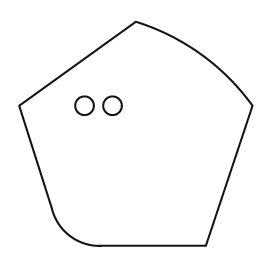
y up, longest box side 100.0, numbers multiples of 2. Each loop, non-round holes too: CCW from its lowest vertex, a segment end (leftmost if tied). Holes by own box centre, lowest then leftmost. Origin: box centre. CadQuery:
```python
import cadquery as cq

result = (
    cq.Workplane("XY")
    .moveTo(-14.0, -48.0)
    .lineTo(30.0, -48.0)
    .lineTo(50.0, 12.0)
    .threePointArc((28.0, 34.0), (0.0, 48.0))
    .lineTo(-50.0, 12.0)
    .lineTo(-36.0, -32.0)
    .threePointArc((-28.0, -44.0), (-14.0, -48.0))
    .close()
    .moveTo(-22.0, 12.0)
    .circle(4.0)
    .moveTo(-10.0, 12.0)
    .circle(4.0)
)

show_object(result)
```